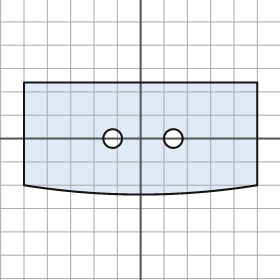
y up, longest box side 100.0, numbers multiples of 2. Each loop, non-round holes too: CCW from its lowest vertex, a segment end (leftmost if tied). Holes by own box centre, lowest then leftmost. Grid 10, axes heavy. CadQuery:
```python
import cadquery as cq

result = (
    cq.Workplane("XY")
    .moveTo(-50.0, -20.0)
    .threePointArc((0.0, -24.0), (50.0, -20.0))
    .lineTo(50.0, 24.0)
    .lineTo(-50.0, 24.0)
    .close()
    .moveTo(-12.0, 0.0)
    .circle(4.0)
    .moveTo(14.0, 0.0)
    .circle(4.0)
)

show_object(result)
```